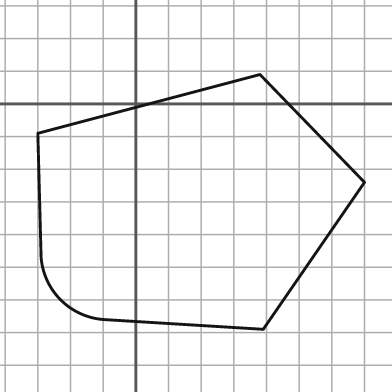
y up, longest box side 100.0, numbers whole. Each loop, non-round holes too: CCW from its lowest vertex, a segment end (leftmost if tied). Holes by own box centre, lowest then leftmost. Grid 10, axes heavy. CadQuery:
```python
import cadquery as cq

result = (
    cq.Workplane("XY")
    .moveTo(39.0, -69.0)
    .lineTo(70.0, -24.0)
    .lineTo(38.0, 9.0)
    .lineTo(-30.0, -9.0)
    .lineTo(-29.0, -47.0)
    .threePointArc((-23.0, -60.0), (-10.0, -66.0))
    .close()
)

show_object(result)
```